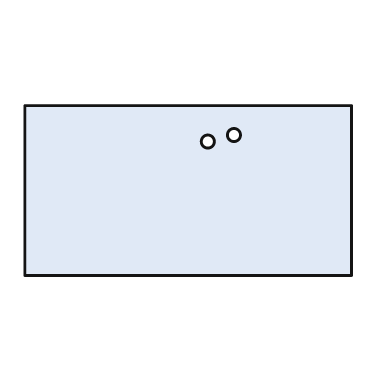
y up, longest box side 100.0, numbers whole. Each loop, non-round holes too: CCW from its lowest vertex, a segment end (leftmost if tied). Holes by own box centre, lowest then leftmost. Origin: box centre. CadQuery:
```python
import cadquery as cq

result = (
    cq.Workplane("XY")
    .moveTo(-50.0, -26.0)
    .lineTo(50.0, -26.0)
    .lineTo(50.0, 26.0)
    .lineTo(-50.0, 26.0)
    .close()
    .moveTo(6.0, 15.0)
    .circle(2.0)
    .moveTo(14.0, 17.0)
    .circle(2.0)
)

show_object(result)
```